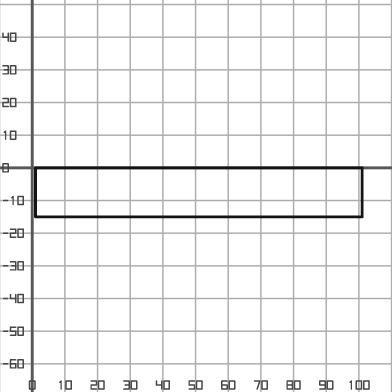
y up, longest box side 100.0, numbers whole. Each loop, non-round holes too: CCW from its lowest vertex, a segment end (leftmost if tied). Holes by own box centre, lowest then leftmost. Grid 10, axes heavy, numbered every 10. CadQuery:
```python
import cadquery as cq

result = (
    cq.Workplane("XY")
    .moveTo(1.0, -15.0)
    .lineTo(101.0, -15.0)
    .lineTo(101.0, 0.0)
    .lineTo(1.0, 0.0)
    .close()
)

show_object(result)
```